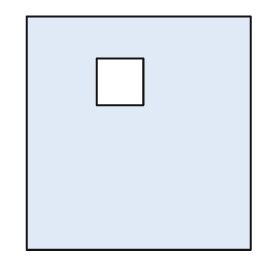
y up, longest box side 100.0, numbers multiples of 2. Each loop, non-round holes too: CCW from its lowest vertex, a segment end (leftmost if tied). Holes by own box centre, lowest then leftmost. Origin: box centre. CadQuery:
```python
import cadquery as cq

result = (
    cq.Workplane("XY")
    .moveTo(-48.0, -50.0)
    .lineTo(48.0, -50.0)
    .lineTo(48.0, 50.0)
    .lineTo(-48.0, 50.0)
    .close()
    .moveTo(-18.0, 12.0)
    .lineTo(2.0, 12.0)
    .lineTo(2.0, 32.0)
    .lineTo(-18.0, 32.0)
    .close()
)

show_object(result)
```